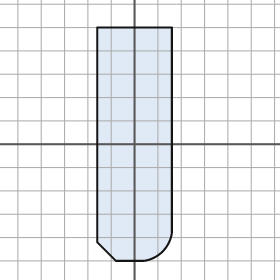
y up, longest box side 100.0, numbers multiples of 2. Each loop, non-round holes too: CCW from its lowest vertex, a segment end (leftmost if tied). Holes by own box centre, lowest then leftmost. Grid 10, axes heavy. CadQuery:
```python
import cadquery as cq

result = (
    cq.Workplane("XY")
    .moveTo(-8.0, -50.0)
    .lineTo(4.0, -50.0)
    .threePointArc((12.0, -46.0), (16.0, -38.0))
    .lineTo(16.0, 50.0)
    .lineTo(-16.0, 50.0)
    .lineTo(-16.0, -42.0)
    .close()
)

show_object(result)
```